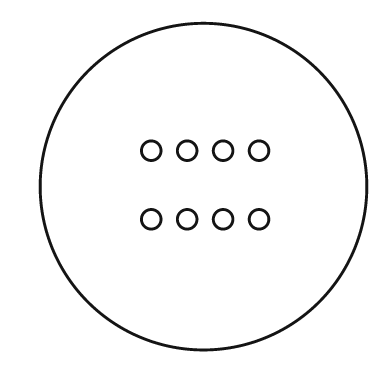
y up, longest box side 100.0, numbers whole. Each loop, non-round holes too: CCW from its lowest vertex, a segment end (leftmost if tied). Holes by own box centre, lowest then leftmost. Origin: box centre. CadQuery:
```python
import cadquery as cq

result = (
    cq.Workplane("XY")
    .moveTo(0.0, 0.0)
    .circle(50.0)
    .moveTo(-16.0, -10.0)
    .circle(3.0)
    .moveTo(-5.0, -10.0)
    .circle(3.0)
    .moveTo(6.0, -10.0)
    .circle(3.0)
    .moveTo(17.0, -10.0)
    .circle(3.0)
    .moveTo(-16.0, 11.0)
    .circle(3.0)
    .moveTo(-5.0, 11.0)
    .circle(3.0)
    .moveTo(6.0, 11.0)
    .circle(3.0)
    .moveTo(17.0, 11.0)
    .circle(3.0)
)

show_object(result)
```